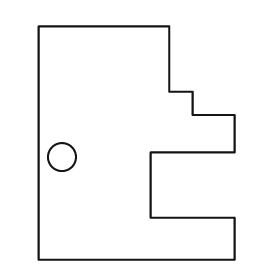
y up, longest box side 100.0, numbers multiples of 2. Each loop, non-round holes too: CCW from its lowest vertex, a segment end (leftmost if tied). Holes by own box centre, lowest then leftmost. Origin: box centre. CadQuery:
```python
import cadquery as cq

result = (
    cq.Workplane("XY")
    .moveTo(-42.0, -50.0)
    .lineTo(42.0, -50.0)
    .lineTo(42.0, -32.0)
    .lineTo(6.0, -32.0)
    .lineTo(6.0, -4.0)
    .lineTo(42.0, -4.0)
    .lineTo(42.0, 12.0)
    .lineTo(24.0, 12.0)
    .lineTo(24.0, 22.0)
    .lineTo(14.0, 22.0)
    .lineTo(14.0, 50.0)
    .lineTo(-42.0, 50.0)
    .close()
    .moveTo(-32.0, -6.0)
    .circle(6.0)
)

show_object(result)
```